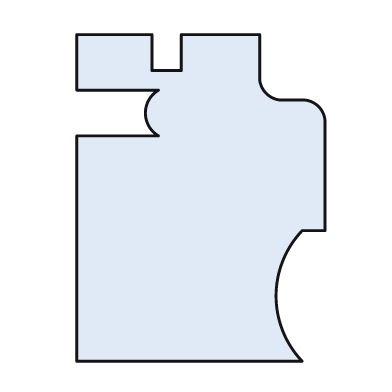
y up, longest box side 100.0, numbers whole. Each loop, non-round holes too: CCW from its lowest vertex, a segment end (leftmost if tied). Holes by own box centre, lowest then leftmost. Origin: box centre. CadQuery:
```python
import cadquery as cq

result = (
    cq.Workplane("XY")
    .moveTo(-38.0, -50.0)
    .lineTo(31.0, -50.0)
    .threePointArc((23.0, -30.0), (31.0, -10.0))
    .lineTo(38.0, -10.0)
    .lineTo(38.0, 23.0)
    .threePointArc((36.0, 28.0), (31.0, 30.0))
    .lineTo(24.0, 30.0)
    .threePointArc((20.0, 32.0), (18.0, 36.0))
    .lineTo(18.0, 50.0)
    .lineTo(-6.0, 50.0)
    .lineTo(-6.0, 39.0)
    .lineTo(-15.0, 39.0)
    .lineTo(-15.0, 50.0)
    .lineTo(-38.0, 50.0)
    .lineTo(-38.0, 33.0)
    .lineTo(-13.0, 33.0)
    .threePointArc((-17.0, 26.0), (-13.0, 19.0))
    .lineTo(-38.0, 19.0)
    .close()
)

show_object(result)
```